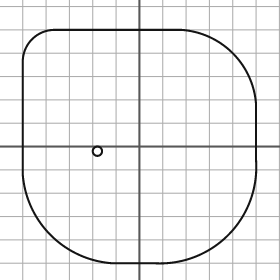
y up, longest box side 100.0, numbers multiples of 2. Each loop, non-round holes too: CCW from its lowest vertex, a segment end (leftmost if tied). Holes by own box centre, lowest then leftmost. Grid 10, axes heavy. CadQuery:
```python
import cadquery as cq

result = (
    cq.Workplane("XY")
    .moveTo(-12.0, -50.0)
    .lineTo(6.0, -50.0)
    .threePointArc((38.0, -38.0), (50.0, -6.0))
    .lineTo(50.0, 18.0)
    .threePointArc((40.0, 40.0), (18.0, 50.0))
    .lineTo(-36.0, 50.0)
    .threePointArc((-46.0, 46.0), (-50.0, 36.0))
    .lineTo(-50.0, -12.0)
    .threePointArc((-38.0, -38.0), (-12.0, -50.0))
    .close()
    .moveTo(-18.0, -2.0)
    .circle(2.0)
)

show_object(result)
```